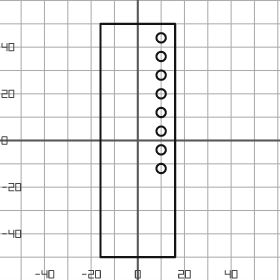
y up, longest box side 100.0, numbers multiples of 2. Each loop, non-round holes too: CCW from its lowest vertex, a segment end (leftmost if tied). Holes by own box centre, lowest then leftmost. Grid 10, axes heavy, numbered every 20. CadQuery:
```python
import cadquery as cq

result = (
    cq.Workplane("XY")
    .moveTo(-16.0, -50.0)
    .lineTo(16.0, -50.0)
    .lineTo(16.0, 50.0)
    .lineTo(-16.0, 50.0)
    .close()
    .moveTo(10.0, -12.0)
    .circle(2.0)
    .moveTo(10.0, -4.0)
    .circle(2.0)
    .moveTo(10.0, 4.0)
    .circle(2.0)
    .moveTo(10.0, 12.0)
    .circle(2.0)
    .moveTo(10.0, 20.0)
    .circle(2.0)
    .moveTo(10.0, 28.0)
    .circle(2.0)
    .moveTo(10.0, 36.0)
    .circle(2.0)
    .moveTo(10.0, 44.0)
    .circle(2.0)
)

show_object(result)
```